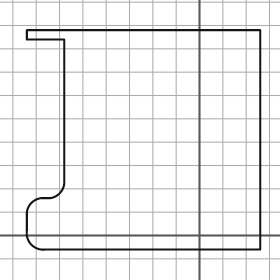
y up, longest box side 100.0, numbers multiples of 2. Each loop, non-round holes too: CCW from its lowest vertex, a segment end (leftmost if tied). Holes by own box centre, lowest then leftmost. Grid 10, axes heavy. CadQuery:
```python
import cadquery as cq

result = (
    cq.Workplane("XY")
    .moveTo(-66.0, -6.0)
    .lineTo(26.0, -6.0)
    .lineTo(26.0, 88.0)
    .lineTo(-74.0, 88.0)
    .lineTo(-74.0, 84.0)
    .lineTo(-58.0, 84.0)
    .lineTo(-58.0, 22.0)
    .threePointArc((-60.0, 18.0), (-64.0, 16.0))
    .lineTo(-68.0, 16.0)
    .threePointArc((-72.0, 14.0), (-74.0, 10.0))
    .lineTo(-74.0, 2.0)
    .threePointArc((-72.0, -4.0), (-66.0, -6.0))
    .close()
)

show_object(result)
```